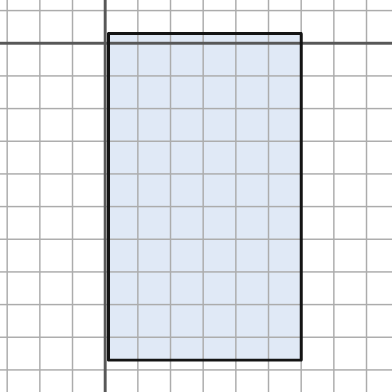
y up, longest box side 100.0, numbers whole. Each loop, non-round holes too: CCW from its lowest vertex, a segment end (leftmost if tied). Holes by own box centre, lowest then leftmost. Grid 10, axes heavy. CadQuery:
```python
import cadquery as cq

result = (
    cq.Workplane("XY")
    .moveTo(1.0, -97.0)
    .lineTo(60.0, -97.0)
    .lineTo(60.0, 3.0)
    .lineTo(1.0, 3.0)
    .close()
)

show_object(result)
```